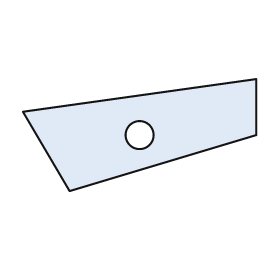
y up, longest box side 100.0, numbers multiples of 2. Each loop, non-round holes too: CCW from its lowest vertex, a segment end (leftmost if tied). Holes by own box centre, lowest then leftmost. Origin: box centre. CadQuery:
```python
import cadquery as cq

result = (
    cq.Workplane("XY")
    .moveTo(-30.0, -24.0)
    .lineTo(50.0, 0.0)
    .lineTo(50.0, 24.0)
    .lineTo(-50.0, 10.0)
    .close()
    .moveTo(0.0, 0.0)
    .circle(6.0)
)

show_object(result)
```